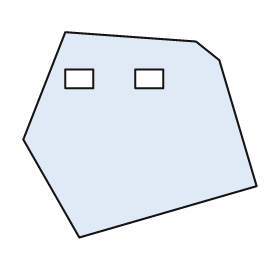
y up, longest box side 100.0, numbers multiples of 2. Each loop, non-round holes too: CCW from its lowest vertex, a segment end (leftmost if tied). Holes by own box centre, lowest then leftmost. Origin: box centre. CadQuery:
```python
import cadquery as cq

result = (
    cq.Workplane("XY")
    .moveTo(-26.0, -44.0)
    .lineTo(50.0, -22.0)
    .lineTo(34.0, 32.0)
    .lineTo(24.0, 40.0)
    .lineTo(-32.0, 44.0)
    .lineTo(-50.0, -2.0)
    .close()
    .moveTo(-32.0, 20.0)
    .lineTo(-20.0, 20.0)
    .lineTo(-20.0, 28.0)
    .lineTo(-32.0, 28.0)
    .close()
    .moveTo(-2.0, 20.0)
    .lineTo(10.0, 20.0)
    .lineTo(10.0, 28.0)
    .lineTo(-2.0, 28.0)
    .close()
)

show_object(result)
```